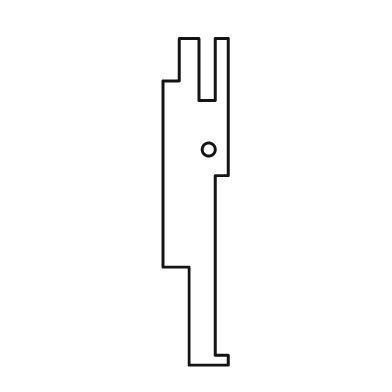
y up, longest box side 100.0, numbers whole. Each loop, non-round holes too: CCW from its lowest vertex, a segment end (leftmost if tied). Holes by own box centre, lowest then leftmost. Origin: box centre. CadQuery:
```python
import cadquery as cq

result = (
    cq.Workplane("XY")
    .moveTo(-2.0, -50.0)
    .lineTo(10.0, -50.0)
    .lineTo(10.0, -47.0)
    .lineTo(6.0, -47.0)
    .lineTo(6.0, 8.0)
    .lineTo(10.0, 8.0)
    .lineTo(10.0, 50.0)
    .lineTo(6.0, 50.0)
    .lineTo(6.0, 31.0)
    .lineTo(1.0, 31.0)
    .lineTo(1.0, 50.0)
    .lineTo(-5.0, 50.0)
    .lineTo(-5.0, 37.0)
    .lineTo(-10.0, 37.0)
    .lineTo(-10.0, -20.0)
    .lineTo(-2.0, -20.0)
    .close()
    .moveTo(4.0, 16.0)
    .circle(2.0)
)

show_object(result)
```